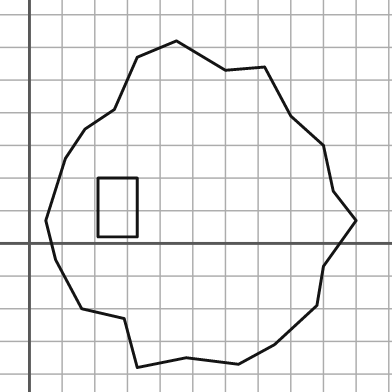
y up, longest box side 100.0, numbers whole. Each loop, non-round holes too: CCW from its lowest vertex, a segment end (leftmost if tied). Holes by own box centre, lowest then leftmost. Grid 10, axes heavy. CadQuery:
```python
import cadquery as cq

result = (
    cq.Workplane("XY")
    .moveTo(33.0, -38.0)
    .lineTo(48.0, -35.0)
    .lineTo(64.0, -37.0)
    .lineTo(75.0, -31.0)
    .lineTo(88.0, -19.0)
    .lineTo(90.0, -7.0)
    .lineTo(100.0, 7.0)
    .lineTo(93.0, 16.0)
    .lineTo(90.0, 30.0)
    .lineTo(80.0, 39.0)
    .lineTo(72.0, 54.0)
    .lineTo(60.0, 53.0)
    .lineTo(45.0, 62.0)
    .lineTo(33.0, 57.0)
    .lineTo(26.0, 41.0)
    .lineTo(17.0, 35.0)
    .lineTo(11.0, 26.0)
    .lineTo(5.0, 7.0)
    .lineTo(8.0, -5.0)
    .lineTo(16.0, -20.0)
    .lineTo(29.0, -23.0)
    .close()
    .moveTo(21.0, 2.0)
    .lineTo(33.0, 2.0)
    .lineTo(33.0, 20.0)
    .lineTo(21.0, 20.0)
    .close()
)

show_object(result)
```